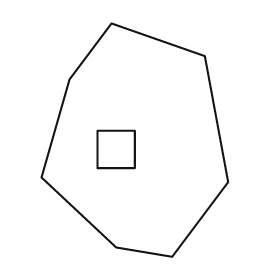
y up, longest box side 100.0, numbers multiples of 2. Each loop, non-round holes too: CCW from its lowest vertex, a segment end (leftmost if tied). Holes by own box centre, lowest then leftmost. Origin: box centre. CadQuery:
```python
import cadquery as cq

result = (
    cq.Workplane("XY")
    .moveTo(16.0, -50.0)
    .lineTo(40.0, -18.0)
    .lineTo(30.0, 36.0)
    .lineTo(-10.0, 50.0)
    .lineTo(-28.0, 26.0)
    .lineTo(-40.0, -16.0)
    .lineTo(-8.0, -46.0)
    .close()
    .moveTo(-16.0, -12.0)
    .lineTo(0.0, -12.0)
    .lineTo(0.0, 4.0)
    .lineTo(-16.0, 4.0)
    .close()
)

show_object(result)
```